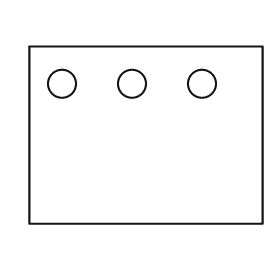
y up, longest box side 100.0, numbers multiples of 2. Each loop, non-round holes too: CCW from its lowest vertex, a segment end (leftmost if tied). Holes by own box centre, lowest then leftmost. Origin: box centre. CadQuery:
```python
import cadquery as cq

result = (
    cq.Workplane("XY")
    .moveTo(-50.0, -38.0)
    .lineTo(50.0, -38.0)
    .lineTo(50.0, 38.0)
    .lineTo(-50.0, 38.0)
    .close()
    .moveTo(-36.0, 22.0)
    .circle(6.0)
    .moveTo(-6.0, 22.0)
    .circle(6.0)
    .moveTo(24.0, 22.0)
    .circle(6.0)
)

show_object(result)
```